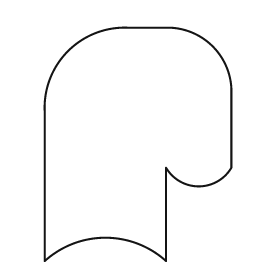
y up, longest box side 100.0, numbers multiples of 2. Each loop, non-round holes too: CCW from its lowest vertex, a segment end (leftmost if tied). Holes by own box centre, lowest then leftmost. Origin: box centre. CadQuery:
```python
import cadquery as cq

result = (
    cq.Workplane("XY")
    .moveTo(-40.0, -50.0)
    .threePointArc((-14.0, -40.0), (12.0, -50.0))
    .lineTo(12.0, -10.0)
    .threePointArc((26.0, -18.0), (40.0, -10.0))
    .lineTo(40.0, 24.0)
    .threePointArc((32.0, 42.0), (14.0, 50.0))
    .lineTo(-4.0, 50.0)
    .threePointArc((-30.0, 40.0), (-40.0, 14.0))
    .close()
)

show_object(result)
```